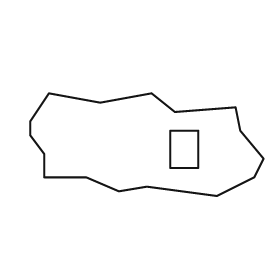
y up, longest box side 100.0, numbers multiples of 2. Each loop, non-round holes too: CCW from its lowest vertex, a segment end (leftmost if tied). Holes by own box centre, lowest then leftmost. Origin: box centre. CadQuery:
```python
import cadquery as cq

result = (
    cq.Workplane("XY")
    .moveTo(30.0, -22.0)
    .lineTo(46.0, -14.0)
    .lineTo(50.0, -6.0)
    .lineTo(40.0, 6.0)
    .lineTo(38.0, 16.0)
    .lineTo(12.0, 14.0)
    .lineTo(2.0, 22.0)
    .lineTo(-20.0, 18.0)
    .lineTo(-42.0, 22.0)
    .lineTo(-50.0, 10.0)
    .lineTo(-50.0, 4.0)
    .lineTo(-44.0, -4.0)
    .lineTo(-44.0, -14.0)
    .lineTo(-26.0, -14.0)
    .lineTo(-12.0, -20.0)
    .lineTo(0.0, -18.0)
    .close()
    .moveTo(10.0, -10.0)
    .lineTo(22.0, -10.0)
    .lineTo(22.0, 6.0)
    .lineTo(10.0, 6.0)
    .close()
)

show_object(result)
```